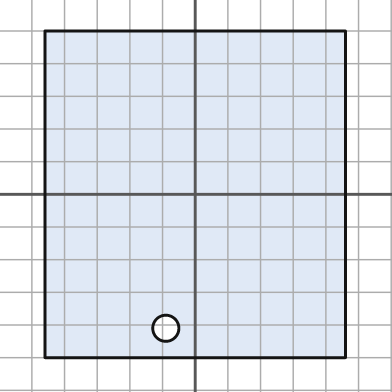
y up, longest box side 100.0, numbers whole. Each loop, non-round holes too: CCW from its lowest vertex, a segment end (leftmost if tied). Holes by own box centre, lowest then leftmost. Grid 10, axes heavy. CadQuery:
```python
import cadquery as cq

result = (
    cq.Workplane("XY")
    .moveTo(-46.0, -50.0)
    .lineTo(46.0, -50.0)
    .lineTo(46.0, 50.0)
    .lineTo(-46.0, 50.0)
    .close()
    .moveTo(-9.0, -41.0)
    .circle(4.0)
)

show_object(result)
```